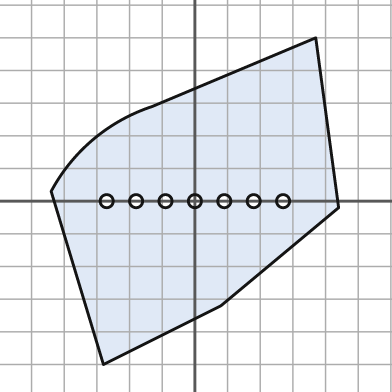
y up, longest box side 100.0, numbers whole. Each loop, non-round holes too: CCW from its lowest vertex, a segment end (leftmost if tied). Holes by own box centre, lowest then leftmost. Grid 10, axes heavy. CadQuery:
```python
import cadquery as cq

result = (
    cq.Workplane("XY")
    .moveTo(-28.0, -50.0)
    .lineTo(8.0, -32.0)
    .lineTo(44.0, -2.0)
    .lineTo(37.0, 50.0)
    .lineTo(-13.0, 29.0)
    .threePointArc((-31.0, 19.0), (-44.0, 3.0))
    .close()
    .moveTo(-27.0, 0.0)
    .circle(2.0)
    .moveTo(-18.0, 0.0)
    .circle(2.0)
    .moveTo(-9.0, 0.0)
    .circle(2.0)
    .moveTo(0.0, 0.0)
    .circle(2.0)
    .moveTo(9.0, 0.0)
    .circle(2.0)
    .moveTo(18.0, 0.0)
    .circle(2.0)
    .moveTo(27.0, 0.0)
    .circle(2.0)
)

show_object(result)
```